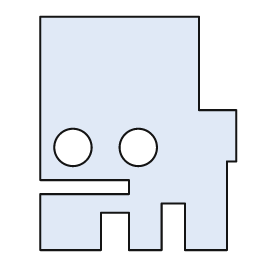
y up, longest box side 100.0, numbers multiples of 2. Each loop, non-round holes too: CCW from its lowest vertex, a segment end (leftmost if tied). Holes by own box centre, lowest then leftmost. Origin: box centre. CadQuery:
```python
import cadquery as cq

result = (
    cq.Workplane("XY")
    .moveTo(-42.0, -50.0)
    .lineTo(-16.0, -50.0)
    .lineTo(-16.0, -34.0)
    .lineTo(-4.0, -34.0)
    .lineTo(-4.0, -50.0)
    .lineTo(10.0, -50.0)
    .lineTo(10.0, -30.0)
    .lineTo(20.0, -30.0)
    .lineTo(20.0, -50.0)
    .lineTo(38.0, -50.0)
    .lineTo(38.0, -12.0)
    .lineTo(42.0, -12.0)
    .lineTo(42.0, 10.0)
    .lineTo(26.0, 10.0)
    .lineTo(26.0, 50.0)
    .lineTo(-42.0, 50.0)
    .lineTo(-42.0, -20.0)
    .lineTo(-4.0, -20.0)
    .lineTo(-4.0, -26.0)
    .lineTo(-42.0, -26.0)
    .close()
    .moveTo(-28.0, -6.0)
    .circle(8.0)
    .moveTo(0.0, -6.0)
    .circle(8.0)
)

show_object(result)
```